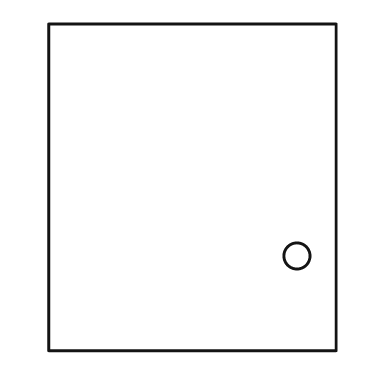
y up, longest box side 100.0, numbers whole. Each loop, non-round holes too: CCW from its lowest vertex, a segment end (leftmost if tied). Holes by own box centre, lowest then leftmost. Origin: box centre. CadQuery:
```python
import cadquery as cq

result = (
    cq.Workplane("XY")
    .moveTo(-44.0, -50.0)
    .lineTo(44.0, -50.0)
    .lineTo(44.0, 50.0)
    .lineTo(-44.0, 50.0)
    .close()
    .moveTo(32.0, -21.0)
    .circle(4.0)
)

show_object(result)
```